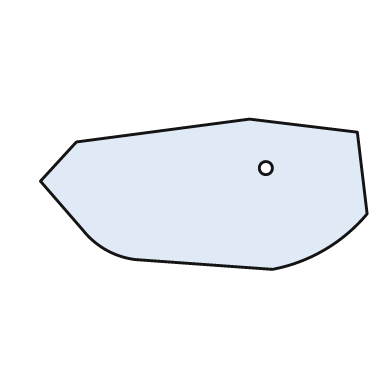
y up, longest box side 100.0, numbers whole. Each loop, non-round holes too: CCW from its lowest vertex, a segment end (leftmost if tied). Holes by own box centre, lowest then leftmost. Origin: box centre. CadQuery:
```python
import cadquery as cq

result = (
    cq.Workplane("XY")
    .moveTo(21.0, -23.0)
    .threePointArc((37.0, -17.0), (50.0, -6.0))
    .lineTo(47.0, 19.0)
    .lineTo(14.0, 23.0)
    .lineTo(-39.0, 16.0)
    .lineTo(-50.0, 4.0)
    .lineTo(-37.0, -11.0)
    .threePointArc((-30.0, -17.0), (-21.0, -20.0))
    .close()
    .moveTo(19.0, 8.0)
    .circle(2.0)
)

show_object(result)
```